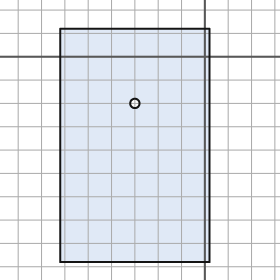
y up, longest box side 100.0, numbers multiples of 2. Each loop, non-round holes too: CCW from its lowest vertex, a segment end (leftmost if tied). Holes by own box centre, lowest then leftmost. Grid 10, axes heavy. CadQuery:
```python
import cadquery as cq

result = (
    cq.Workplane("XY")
    .moveTo(-62.0, -88.0)
    .lineTo(2.0, -88.0)
    .lineTo(2.0, 12.0)
    .lineTo(-62.0, 12.0)
    .close()
    .moveTo(-30.0, -20.0)
    .circle(2.0)
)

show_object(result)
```